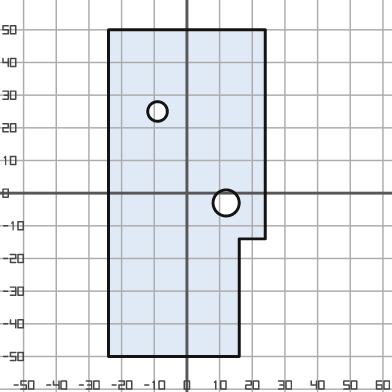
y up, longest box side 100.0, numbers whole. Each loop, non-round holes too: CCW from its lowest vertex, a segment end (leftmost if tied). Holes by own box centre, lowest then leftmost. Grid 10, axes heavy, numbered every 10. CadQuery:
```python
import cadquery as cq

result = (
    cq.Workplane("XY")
    .moveTo(-24.0, -50.0)
    .lineTo(16.0, -50.0)
    .lineTo(16.0, -14.0)
    .lineTo(24.0, -14.0)
    .lineTo(24.0, 50.0)
    .lineTo(-24.0, 50.0)
    .close()
    .moveTo(12.0, -3.0)
    .circle(4.0)
    .moveTo(-9.0, 25.0)
    .circle(3.0)
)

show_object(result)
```